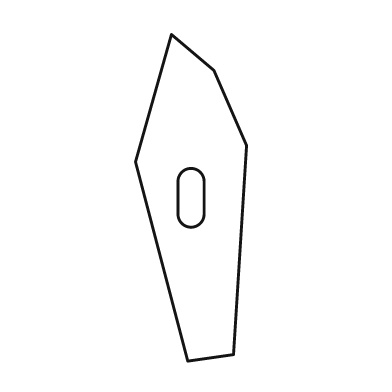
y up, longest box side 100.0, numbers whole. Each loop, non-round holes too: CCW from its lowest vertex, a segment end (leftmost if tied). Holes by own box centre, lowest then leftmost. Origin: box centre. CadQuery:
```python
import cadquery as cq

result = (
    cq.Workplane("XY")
    .moveTo(-1.0, -50.0)
    .lineTo(13.0, -48.0)
    .lineTo(17.0, 16.0)
    .lineTo(7.0, 39.0)
    .lineTo(-6.0, 50.0)
    .lineTo(-17.0, 11.0)
    .close()
    .moveTo(-4.0, -5.0)
    .threePointArc((0.0, -9.0), (4.0, -5.0))
    .lineTo(4.0, 5.0)
    .threePointArc((0.0, 9.0), (-4.0, 5.0))
    .close()
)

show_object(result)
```